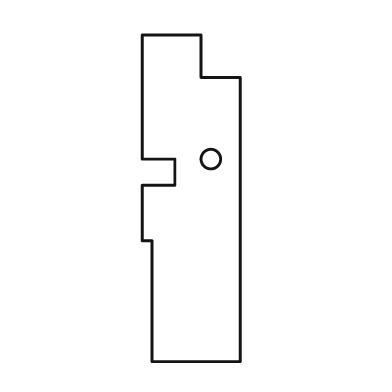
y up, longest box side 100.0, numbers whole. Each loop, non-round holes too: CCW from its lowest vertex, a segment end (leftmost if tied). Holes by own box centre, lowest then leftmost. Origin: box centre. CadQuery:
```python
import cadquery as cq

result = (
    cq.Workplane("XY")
    .moveTo(-12.0, -50.0)
    .lineTo(15.0, -50.0)
    .lineTo(15.0, 37.0)
    .lineTo(3.0, 37.0)
    .lineTo(3.0, 50.0)
    .lineTo(-15.0, 50.0)
    .lineTo(-15.0, 12.0)
    .lineTo(-5.0, 12.0)
    .lineTo(-5.0, 4.0)
    .lineTo(-15.0, 4.0)
    .lineTo(-15.0, -13.0)
    .lineTo(-12.0, -13.0)
    .close()
    .moveTo(6.0, 12.0)
    .circle(3.0)
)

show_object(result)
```